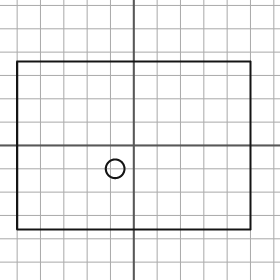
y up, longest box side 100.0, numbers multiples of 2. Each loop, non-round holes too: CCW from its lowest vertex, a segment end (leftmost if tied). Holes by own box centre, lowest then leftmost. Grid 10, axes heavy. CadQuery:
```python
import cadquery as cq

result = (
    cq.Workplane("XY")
    .moveTo(-50.0, -36.0)
    .lineTo(50.0, -36.0)
    .lineTo(50.0, 36.0)
    .lineTo(-50.0, 36.0)
    .close()
    .moveTo(-8.0, -10.0)
    .circle(4.0)
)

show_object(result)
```